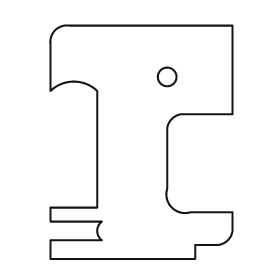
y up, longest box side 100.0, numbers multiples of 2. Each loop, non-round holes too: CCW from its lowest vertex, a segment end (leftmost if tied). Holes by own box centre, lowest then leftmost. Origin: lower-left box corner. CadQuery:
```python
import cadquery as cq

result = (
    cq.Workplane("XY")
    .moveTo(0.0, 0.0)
    .lineTo(62.0, 0.0)
    .lineTo(62.0, 6.0)
    .lineTo(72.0, 6.0)
    .threePointArc((76.0, 8.0), (78.0, 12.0))
    .lineTo(78.0, 20.0)
    .lineTo(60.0, 20.0)
    .threePointArc((52.0, 22.0), (50.0, 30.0))
    .lineTo(50.0, 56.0)
    .threePointArc((52.0, 60.0), (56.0, 62.0))
    .lineTo(78.0, 62.0)
    .lineTo(78.0, 100.0)
    .lineTo(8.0, 100.0)
    .threePointArc((2.0, 98.0), (0.0, 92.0))
    .lineTo(0.0, 72.0)
    .threePointArc((10.0, 76.0), (20.0, 72.0))
    .lineTo(20.0, 22.0)
    .lineTo(0.0, 22.0)
    .lineTo(0.0, 16.0)
    .lineTo(22.0, 16.0)
    .threePointArc((20.0, 12.0), (22.0, 8.0))
    .lineTo(0.0, 8.0)
    .close()
    .moveTo(50.0, 78.0)
    .circle(4.0)
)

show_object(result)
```